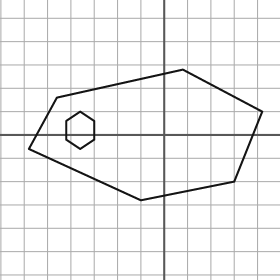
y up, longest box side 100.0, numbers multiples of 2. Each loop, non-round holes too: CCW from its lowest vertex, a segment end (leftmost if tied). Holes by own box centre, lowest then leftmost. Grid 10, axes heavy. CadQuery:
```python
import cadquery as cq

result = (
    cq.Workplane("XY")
    .moveTo(-10.0, -28.0)
    .lineTo(30.0, -20.0)
    .lineTo(42.0, 10.0)
    .lineTo(8.0, 28.0)
    .lineTo(-46.0, 16.0)
    .lineTo(-58.0, -6.0)
    .close()
    .moveTo(-36.0, -6.0)
    .lineTo(-30.0, -2.0)
    .lineTo(-30.0, 6.0)
    .lineTo(-36.0, 10.0)
    .lineTo(-42.0, 6.0)
    .lineTo(-42.0, -2.0)
    .close()
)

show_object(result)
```